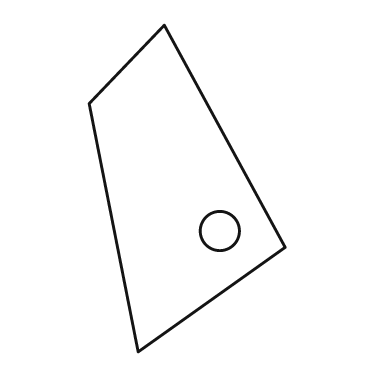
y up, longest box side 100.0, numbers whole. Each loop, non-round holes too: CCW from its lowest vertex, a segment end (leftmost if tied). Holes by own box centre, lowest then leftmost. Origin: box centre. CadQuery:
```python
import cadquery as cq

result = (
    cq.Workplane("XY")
    .moveTo(-15.0, -50.0)
    .lineTo(30.0, -18.0)
    .lineTo(-7.0, 50.0)
    .lineTo(-30.0, 26.0)
    .close()
    .moveTo(10.0, -13.0)
    .circle(6.0)
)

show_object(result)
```